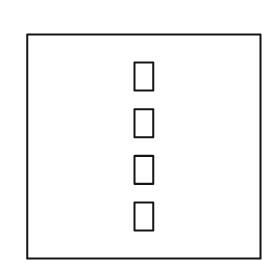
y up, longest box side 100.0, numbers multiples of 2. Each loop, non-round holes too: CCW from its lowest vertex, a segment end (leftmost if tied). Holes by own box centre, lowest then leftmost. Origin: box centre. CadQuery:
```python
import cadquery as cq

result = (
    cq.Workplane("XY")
    .moveTo(-50.0, -48.0)
    .lineTo(50.0, -48.0)
    .lineTo(50.0, 48.0)
    .lineTo(-50.0, 48.0)
    .close()
    .moveTo(-4.0, -36.0)
    .lineTo(4.0, -36.0)
    .lineTo(4.0, -24.0)
    .lineTo(-4.0, -24.0)
    .close()
    .moveTo(-4.0, -16.0)
    .lineTo(4.0, -16.0)
    .lineTo(4.0, -4.0)
    .lineTo(-4.0, -4.0)
    .close()
    .moveTo(-4.0, 4.0)
    .lineTo(4.0, 4.0)
    .lineTo(4.0, 16.0)
    .lineTo(-4.0, 16.0)
    .close()
    .moveTo(-4.0, 24.0)
    .lineTo(4.0, 24.0)
    .lineTo(4.0, 36.0)
    .lineTo(-4.0, 36.0)
    .close()
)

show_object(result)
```